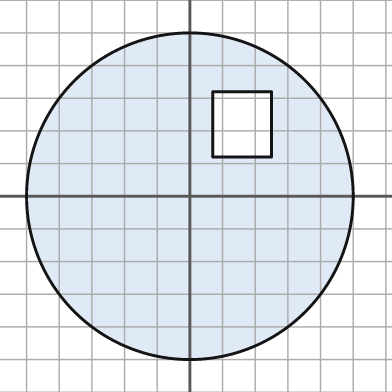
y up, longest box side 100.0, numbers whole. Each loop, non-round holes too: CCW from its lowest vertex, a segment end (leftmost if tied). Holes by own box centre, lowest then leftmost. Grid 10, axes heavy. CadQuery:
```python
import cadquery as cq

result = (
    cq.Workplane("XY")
    .moveTo(0.0, 0.0)
    .circle(50.0)
    .moveTo(7.0, 12.0)
    .lineTo(25.0, 12.0)
    .lineTo(25.0, 32.0)
    .lineTo(7.0, 32.0)
    .close()
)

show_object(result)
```